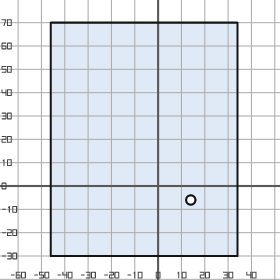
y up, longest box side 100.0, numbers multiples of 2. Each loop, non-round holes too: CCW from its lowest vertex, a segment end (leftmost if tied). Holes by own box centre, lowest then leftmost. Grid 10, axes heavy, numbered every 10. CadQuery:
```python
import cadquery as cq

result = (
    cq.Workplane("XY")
    .moveTo(-46.0, -30.0)
    .lineTo(34.0, -30.0)
    .lineTo(34.0, 70.0)
    .lineTo(-46.0, 70.0)
    .close()
    .moveTo(14.0, -6.0)
    .circle(2.0)
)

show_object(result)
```